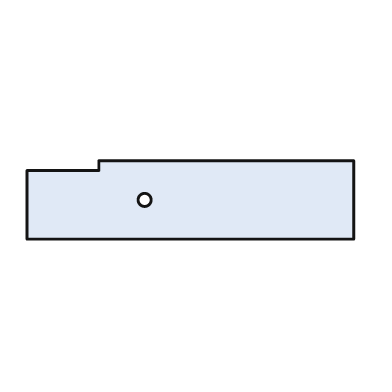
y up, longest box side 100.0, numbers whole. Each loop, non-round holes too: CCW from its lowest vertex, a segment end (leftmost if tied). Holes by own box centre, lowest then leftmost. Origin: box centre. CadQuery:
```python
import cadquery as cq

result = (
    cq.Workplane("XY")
    .moveTo(-50.0, -12.0)
    .lineTo(50.0, -12.0)
    .lineTo(50.0, 12.0)
    .lineTo(-28.0, 12.0)
    .lineTo(-28.0, 9.0)
    .lineTo(-50.0, 9.0)
    .close()
    .moveTo(-14.0, 0.0)
    .circle(2.0)
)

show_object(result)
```